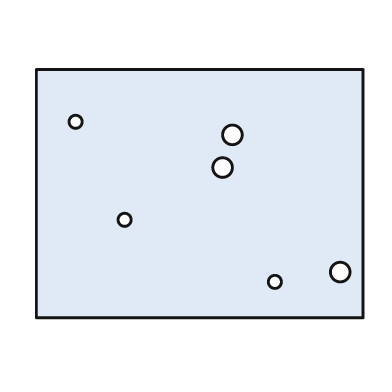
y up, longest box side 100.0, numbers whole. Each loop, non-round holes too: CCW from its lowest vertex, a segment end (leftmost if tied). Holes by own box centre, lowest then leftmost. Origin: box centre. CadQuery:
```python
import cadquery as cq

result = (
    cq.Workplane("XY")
    .moveTo(-50.0, -38.0)
    .lineTo(50.0, -38.0)
    .lineTo(50.0, 38.0)
    .lineTo(-50.0, 38.0)
    .close()
    .moveTo(23.0, -27.0)
    .circle(2.0)
    .moveTo(43.0, -24.0)
    .circle(3.0)
    .moveTo(-23.0, -8.0)
    .circle(2.0)
    .moveTo(7.0, 8.0)
    .circle(3.0)
    .moveTo(10.0, 18.0)
    .circle(3.0)
    .moveTo(-38.0, 22.0)
    .circle(2.0)
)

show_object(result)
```